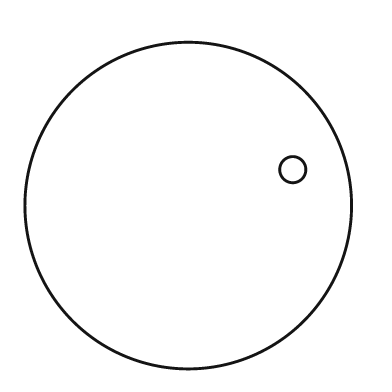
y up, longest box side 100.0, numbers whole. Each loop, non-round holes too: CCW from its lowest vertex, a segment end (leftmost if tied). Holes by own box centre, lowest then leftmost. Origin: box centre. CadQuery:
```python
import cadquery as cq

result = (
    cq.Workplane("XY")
    .moveTo(0.0, 0.0)
    .circle(50.0)
    .moveTo(32.0, 11.0)
    .circle(4.0)
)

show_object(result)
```